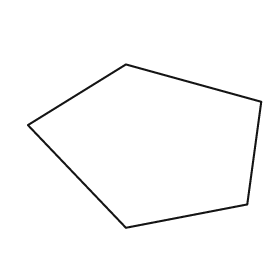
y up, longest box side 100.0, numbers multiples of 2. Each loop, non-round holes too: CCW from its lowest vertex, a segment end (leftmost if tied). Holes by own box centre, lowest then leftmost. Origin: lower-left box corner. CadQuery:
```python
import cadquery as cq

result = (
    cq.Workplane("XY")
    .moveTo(42.0, 0.0)
    .lineTo(94.0, 10.0)
    .lineTo(100.0, 54.0)
    .lineTo(42.0, 70.0)
    .lineTo(0.0, 44.0)
    .close()
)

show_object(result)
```